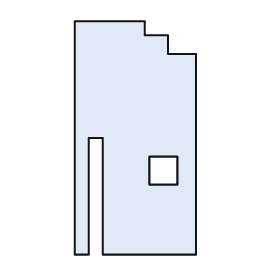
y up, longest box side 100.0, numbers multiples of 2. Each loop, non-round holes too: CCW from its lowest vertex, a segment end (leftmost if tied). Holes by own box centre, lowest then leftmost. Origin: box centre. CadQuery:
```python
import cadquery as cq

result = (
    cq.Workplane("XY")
    .moveTo(-26.0, -50.0)
    .lineTo(-20.0, -50.0)
    .lineTo(-20.0, 0.0)
    .lineTo(-14.0, 0.0)
    .lineTo(-14.0, -50.0)
    .lineTo(26.0, -50.0)
    .lineTo(26.0, 36.0)
    .lineTo(14.0, 36.0)
    .lineTo(14.0, 44.0)
    .lineTo(4.0, 44.0)
    .lineTo(4.0, 50.0)
    .lineTo(-26.0, 50.0)
    .close()
    .moveTo(6.0, -20.0)
    .lineTo(18.0, -20.0)
    .lineTo(18.0, -8.0)
    .lineTo(6.0, -8.0)
    .close()
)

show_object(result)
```